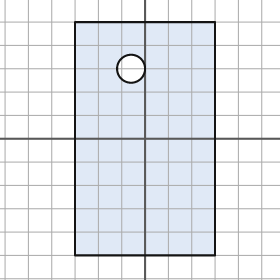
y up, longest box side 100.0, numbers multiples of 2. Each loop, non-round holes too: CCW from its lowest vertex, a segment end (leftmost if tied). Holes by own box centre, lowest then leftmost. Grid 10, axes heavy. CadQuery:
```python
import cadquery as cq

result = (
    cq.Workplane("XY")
    .moveTo(-30.0, -50.0)
    .lineTo(30.0, -50.0)
    .lineTo(30.0, 50.0)
    .lineTo(-30.0, 50.0)
    .close()
    .moveTo(-6.0, 30.0)
    .circle(6.0)
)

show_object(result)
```